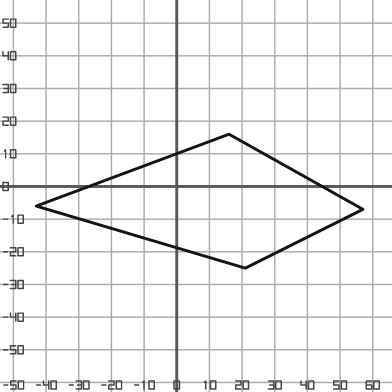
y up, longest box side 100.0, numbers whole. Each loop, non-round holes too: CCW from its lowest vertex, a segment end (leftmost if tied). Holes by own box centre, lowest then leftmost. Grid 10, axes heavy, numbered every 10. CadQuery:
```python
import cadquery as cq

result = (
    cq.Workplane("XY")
    .moveTo(21.0, -25.0)
    .lineTo(57.0, -7.0)
    .lineTo(16.0, 16.0)
    .lineTo(-43.0, -6.0)
    .close()
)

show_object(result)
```